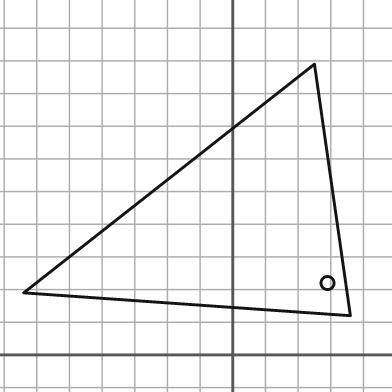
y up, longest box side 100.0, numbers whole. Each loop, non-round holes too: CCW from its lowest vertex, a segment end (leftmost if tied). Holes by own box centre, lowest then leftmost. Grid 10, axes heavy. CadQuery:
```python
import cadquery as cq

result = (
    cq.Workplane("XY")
    .moveTo(36.0, 12.0)
    .lineTo(25.0, 89.0)
    .lineTo(-64.0, 19.0)
    .close()
    .moveTo(29.0, 22.0)
    .circle(2.0)
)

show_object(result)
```